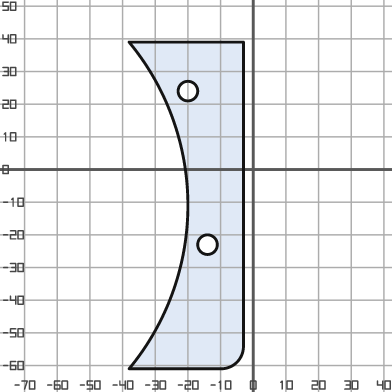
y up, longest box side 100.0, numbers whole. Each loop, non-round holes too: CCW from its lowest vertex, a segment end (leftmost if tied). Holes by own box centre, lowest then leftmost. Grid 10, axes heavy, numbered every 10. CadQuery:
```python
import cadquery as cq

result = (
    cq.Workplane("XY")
    .moveTo(-38.0, -61.0)
    .lineTo(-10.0, -61.0)
    .threePointArc((-5.0, -59.0), (-3.0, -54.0))
    .lineTo(-3.0, 39.0)
    .lineTo(-38.0, 39.0)
    .threePointArc((-20.0, -11.0), (-38.0, -61.0))
    .close()
    .moveTo(-14.0, -23.0)
    .circle(3.0)
    .moveTo(-20.0, 24.0)
    .circle(3.0)
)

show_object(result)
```